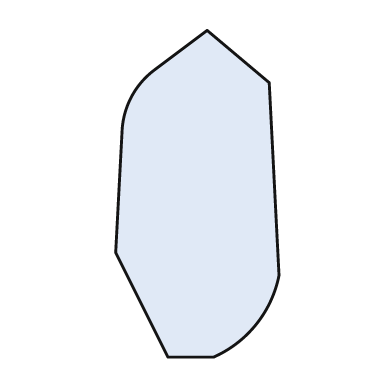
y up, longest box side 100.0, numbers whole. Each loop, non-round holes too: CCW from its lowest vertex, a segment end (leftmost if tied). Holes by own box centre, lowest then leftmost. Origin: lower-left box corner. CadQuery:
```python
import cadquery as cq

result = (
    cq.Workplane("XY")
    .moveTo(16.0, 0.0)
    .lineTo(30.0, 0.0)
    .threePointArc((43.0, 10.0), (50.0, 25.0))
    .lineTo(47.0, 84.0)
    .lineTo(28.0, 100.0)
    .lineTo(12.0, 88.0)
    .threePointArc((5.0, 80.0), (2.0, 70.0))
    .lineTo(0.0, 32.0)
    .close()
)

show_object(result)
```